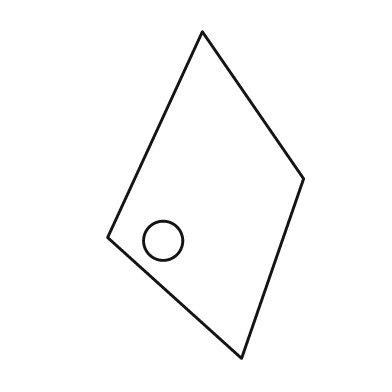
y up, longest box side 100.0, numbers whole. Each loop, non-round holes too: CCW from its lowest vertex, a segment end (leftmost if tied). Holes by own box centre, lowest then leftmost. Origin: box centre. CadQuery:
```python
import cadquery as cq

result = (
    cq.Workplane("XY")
    .moveTo(11.0, -50.0)
    .lineTo(30.0, 5.0)
    .lineTo(-1.0, 50.0)
    .lineTo(-30.0, -13.0)
    .close()
    .moveTo(-13.0, -14.0)
    .circle(6.0)
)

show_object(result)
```